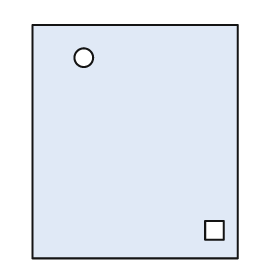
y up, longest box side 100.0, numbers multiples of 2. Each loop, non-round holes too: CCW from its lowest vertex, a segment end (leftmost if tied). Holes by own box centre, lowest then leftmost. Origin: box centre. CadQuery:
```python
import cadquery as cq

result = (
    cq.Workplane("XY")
    .moveTo(-44.0, -50.0)
    .lineTo(44.0, -50.0)
    .lineTo(44.0, 50.0)
    .lineTo(-44.0, 50.0)
    .close()
    .moveTo(30.0, -42.0)
    .lineTo(38.0, -42.0)
    .lineTo(38.0, -34.0)
    .lineTo(30.0, -34.0)
    .close()
    .moveTo(-22.0, 36.0)
    .circle(4.0)
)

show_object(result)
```